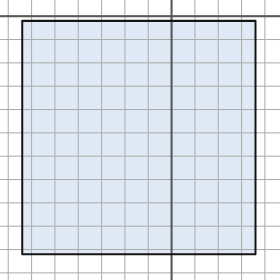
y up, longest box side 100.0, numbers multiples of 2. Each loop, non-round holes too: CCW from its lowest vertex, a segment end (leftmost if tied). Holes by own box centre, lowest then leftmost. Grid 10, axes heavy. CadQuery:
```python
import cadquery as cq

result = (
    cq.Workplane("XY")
    .moveTo(-64.0, -102.0)
    .lineTo(36.0, -102.0)
    .lineTo(36.0, -2.0)
    .lineTo(-64.0, -2.0)
    .close()
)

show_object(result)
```